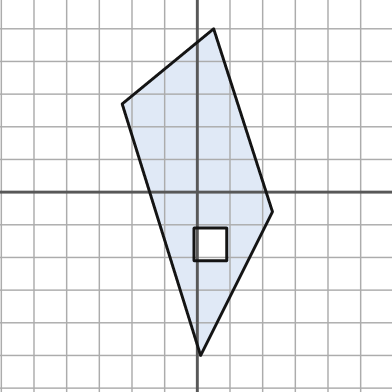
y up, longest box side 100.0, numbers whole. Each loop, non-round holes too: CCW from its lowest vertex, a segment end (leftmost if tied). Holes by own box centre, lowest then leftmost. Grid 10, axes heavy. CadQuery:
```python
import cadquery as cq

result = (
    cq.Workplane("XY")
    .moveTo(1.0, -50.0)
    .lineTo(23.0, -6.0)
    .lineTo(5.0, 50.0)
    .lineTo(-23.0, 27.0)
    .close()
    .moveTo(-1.0, -21.0)
    .lineTo(9.0, -21.0)
    .lineTo(9.0, -11.0)
    .lineTo(-1.0, -11.0)
    .close()
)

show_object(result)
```